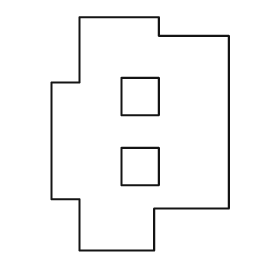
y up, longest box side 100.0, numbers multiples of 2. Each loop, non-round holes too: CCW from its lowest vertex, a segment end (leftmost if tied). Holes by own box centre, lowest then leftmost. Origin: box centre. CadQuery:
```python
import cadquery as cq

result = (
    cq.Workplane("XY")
    .moveTo(-26.0, -50.0)
    .lineTo(6.0, -50.0)
    .lineTo(6.0, -32.0)
    .lineTo(38.0, -32.0)
    .lineTo(38.0, 42.0)
    .lineTo(8.0, 42.0)
    .lineTo(8.0, 50.0)
    .lineTo(-26.0, 50.0)
    .lineTo(-26.0, 22.0)
    .lineTo(-38.0, 22.0)
    .lineTo(-38.0, -28.0)
    .lineTo(-26.0, -28.0)
    .close()
    .moveTo(-8.0, -22.0)
    .lineTo(8.0, -22.0)
    .lineTo(8.0, -6.0)
    .lineTo(-8.0, -6.0)
    .close()
    .moveTo(-8.0, 8.0)
    .lineTo(8.0, 8.0)
    .lineTo(8.0, 24.0)
    .lineTo(-8.0, 24.0)
    .close()
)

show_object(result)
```